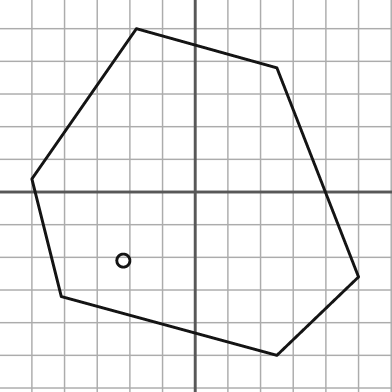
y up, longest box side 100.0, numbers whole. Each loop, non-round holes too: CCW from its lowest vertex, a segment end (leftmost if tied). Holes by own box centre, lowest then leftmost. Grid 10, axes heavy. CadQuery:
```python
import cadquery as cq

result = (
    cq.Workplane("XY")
    .moveTo(25.0, -50.0)
    .lineTo(50.0, -26.0)
    .lineTo(25.0, 38.0)
    .lineTo(-18.0, 50.0)
    .lineTo(-50.0, 4.0)
    .lineTo(-41.0, -32.0)
    .close()
    .moveTo(-22.0, -21.0)
    .circle(2.0)
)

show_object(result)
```